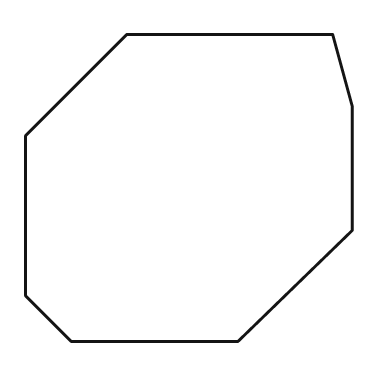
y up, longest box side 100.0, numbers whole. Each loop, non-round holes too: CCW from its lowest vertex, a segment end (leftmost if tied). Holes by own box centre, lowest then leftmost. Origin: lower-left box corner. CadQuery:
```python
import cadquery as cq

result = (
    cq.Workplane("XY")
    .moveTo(14.0, 0.0)
    .lineTo(65.0, 0.0)
    .lineTo(100.0, 34.0)
    .lineTo(100.0, 72.0)
    .lineTo(94.0, 94.0)
    .lineTo(31.0, 94.0)
    .lineTo(0.0, 63.0)
    .lineTo(0.0, 14.0)
    .close()
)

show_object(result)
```